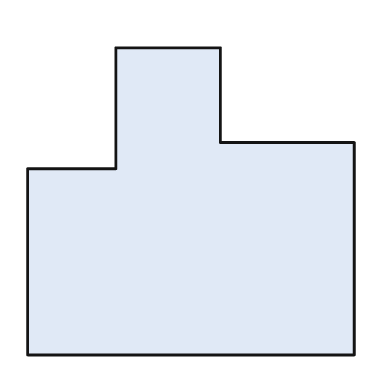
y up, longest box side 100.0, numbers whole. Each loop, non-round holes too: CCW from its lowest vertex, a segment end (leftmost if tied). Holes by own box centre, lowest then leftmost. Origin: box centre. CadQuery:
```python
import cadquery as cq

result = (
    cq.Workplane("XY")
    .moveTo(-50.0, -47.0)
    .lineTo(50.0, -47.0)
    .lineTo(50.0, 18.0)
    .lineTo(9.0, 18.0)
    .lineTo(9.0, 47.0)
    .lineTo(-23.0, 47.0)
    .lineTo(-23.0, 10.0)
    .lineTo(-50.0, 10.0)
    .close()
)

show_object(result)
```